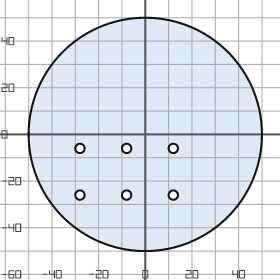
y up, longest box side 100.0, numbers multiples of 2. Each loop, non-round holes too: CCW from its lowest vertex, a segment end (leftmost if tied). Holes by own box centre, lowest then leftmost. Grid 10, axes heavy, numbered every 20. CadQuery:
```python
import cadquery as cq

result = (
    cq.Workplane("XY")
    .moveTo(0.0, 0.0)
    .circle(50.0)
    .moveTo(-28.0, -26.0)
    .circle(2.0)
    .moveTo(-8.0, -26.0)
    .circle(2.0)
    .moveTo(12.0, -26.0)
    .circle(2.0)
    .moveTo(-28.0, -6.0)
    .circle(2.0)
    .moveTo(-8.0, -6.0)
    .circle(2.0)
    .moveTo(12.0, -6.0)
    .circle(2.0)
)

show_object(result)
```